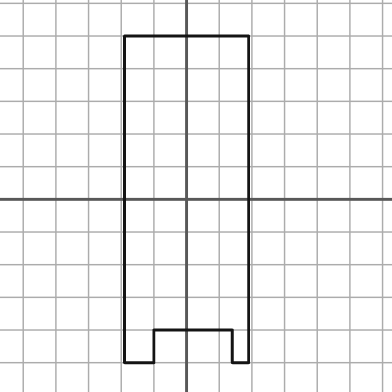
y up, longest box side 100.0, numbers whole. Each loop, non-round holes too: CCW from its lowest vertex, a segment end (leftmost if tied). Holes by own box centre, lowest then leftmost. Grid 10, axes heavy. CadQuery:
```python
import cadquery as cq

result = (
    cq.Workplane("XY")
    .moveTo(-19.0, -50.0)
    .lineTo(-10.0, -50.0)
    .lineTo(-10.0, -40.0)
    .lineTo(14.0, -40.0)
    .lineTo(14.0, -50.0)
    .lineTo(19.0, -50.0)
    .lineTo(19.0, 50.0)
    .lineTo(-19.0, 50.0)
    .close()
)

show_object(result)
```